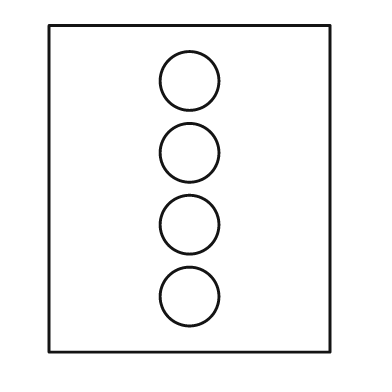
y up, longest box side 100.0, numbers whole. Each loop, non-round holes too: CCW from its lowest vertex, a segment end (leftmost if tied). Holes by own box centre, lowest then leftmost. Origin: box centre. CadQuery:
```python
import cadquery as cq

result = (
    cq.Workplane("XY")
    .moveTo(-43.0, -50.0)
    .lineTo(43.0, -50.0)
    .lineTo(43.0, 50.0)
    .lineTo(-43.0, 50.0)
    .close()
    .moveTo(0.0, -33.0)
    .circle(9.0)
    .moveTo(0.0, -11.0)
    .circle(9.0)
    .moveTo(0.0, 11.0)
    .circle(9.0)
    .moveTo(0.0, 33.0)
    .circle(9.0)
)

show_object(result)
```